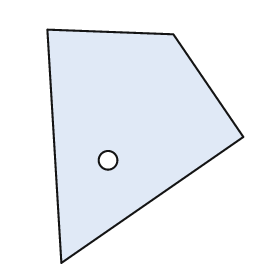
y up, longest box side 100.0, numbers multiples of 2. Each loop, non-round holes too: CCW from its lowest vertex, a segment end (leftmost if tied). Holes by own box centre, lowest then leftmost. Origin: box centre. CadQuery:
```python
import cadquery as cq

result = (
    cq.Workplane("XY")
    .moveTo(-36.0, -50.0)
    .lineTo(42.0, 4.0)
    .lineTo(12.0, 48.0)
    .lineTo(-42.0, 50.0)
    .close()
    .moveTo(-16.0, -6.0)
    .circle(4.0)
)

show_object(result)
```